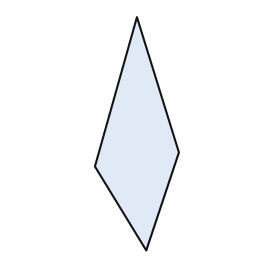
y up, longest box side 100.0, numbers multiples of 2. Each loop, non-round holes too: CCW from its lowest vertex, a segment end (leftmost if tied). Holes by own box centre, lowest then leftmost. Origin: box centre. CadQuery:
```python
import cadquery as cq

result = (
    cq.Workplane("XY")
    .moveTo(4.0, -50.0)
    .lineTo(18.0, -8.0)
    .lineTo(0.0, 50.0)
    .lineTo(-18.0, -14.0)
    .close()
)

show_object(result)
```